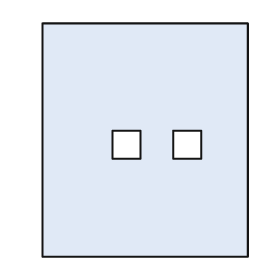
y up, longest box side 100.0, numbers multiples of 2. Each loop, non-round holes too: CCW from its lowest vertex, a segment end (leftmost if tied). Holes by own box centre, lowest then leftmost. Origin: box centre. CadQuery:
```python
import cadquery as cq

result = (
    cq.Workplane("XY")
    .moveTo(-44.0, -50.0)
    .lineTo(44.0, -50.0)
    .lineTo(44.0, 50.0)
    .lineTo(-44.0, 50.0)
    .close()
    .moveTo(-14.0, -8.0)
    .lineTo(-2.0, -8.0)
    .lineTo(-2.0, 4.0)
    .lineTo(-14.0, 4.0)
    .close()
    .moveTo(12.0, -8.0)
    .lineTo(24.0, -8.0)
    .lineTo(24.0, 4.0)
    .lineTo(12.0, 4.0)
    .close()
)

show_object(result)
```